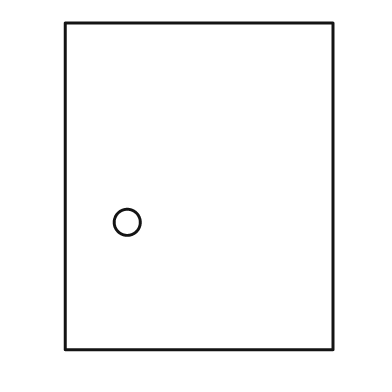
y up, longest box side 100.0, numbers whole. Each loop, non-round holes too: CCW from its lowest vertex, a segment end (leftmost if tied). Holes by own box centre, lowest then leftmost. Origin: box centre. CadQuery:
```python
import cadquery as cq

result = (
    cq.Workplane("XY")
    .moveTo(-41.0, -50.0)
    .lineTo(41.0, -50.0)
    .lineTo(41.0, 50.0)
    .lineTo(-41.0, 50.0)
    .close()
    .moveTo(-22.0, -11.0)
    .circle(4.0)
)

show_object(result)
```